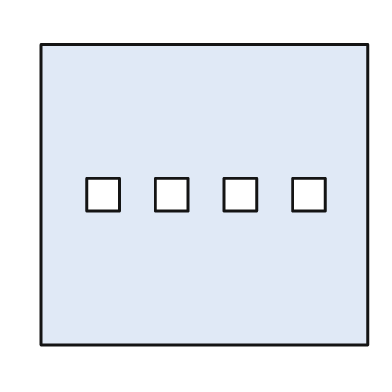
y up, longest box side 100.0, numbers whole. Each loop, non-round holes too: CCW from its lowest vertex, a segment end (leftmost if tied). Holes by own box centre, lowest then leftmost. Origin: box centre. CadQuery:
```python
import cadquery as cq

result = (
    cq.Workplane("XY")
    .moveTo(-50.0, -46.0)
    .lineTo(50.0, -46.0)
    .lineTo(50.0, 46.0)
    .lineTo(-50.0, 46.0)
    .close()
    .moveTo(-36.0, -5.0)
    .lineTo(-26.0, -5.0)
    .lineTo(-26.0, 5.0)
    .lineTo(-36.0, 5.0)
    .close()
    .moveTo(-15.0, -5.0)
    .lineTo(-5.0, -5.0)
    .lineTo(-5.0, 5.0)
    .lineTo(-15.0, 5.0)
    .close()
    .moveTo(6.0, -5.0)
    .lineTo(16.0, -5.0)
    .lineTo(16.0, 5.0)
    .lineTo(6.0, 5.0)
    .close()
    .moveTo(27.0, -5.0)
    .lineTo(37.0, -5.0)
    .lineTo(37.0, 5.0)
    .lineTo(27.0, 5.0)
    .close()
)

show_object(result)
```